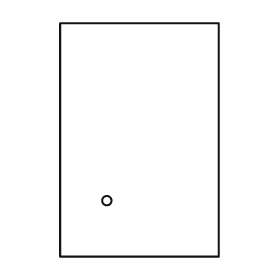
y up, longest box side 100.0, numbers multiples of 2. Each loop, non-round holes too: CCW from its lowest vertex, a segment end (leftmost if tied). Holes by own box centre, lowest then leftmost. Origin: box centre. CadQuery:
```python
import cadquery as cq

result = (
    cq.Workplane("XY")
    .moveTo(-34.0, -50.0)
    .lineTo(34.0, -50.0)
    .lineTo(34.0, 50.0)
    .lineTo(-34.0, 50.0)
    .close()
    .moveTo(-14.0, -26.0)
    .circle(2.0)
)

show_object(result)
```